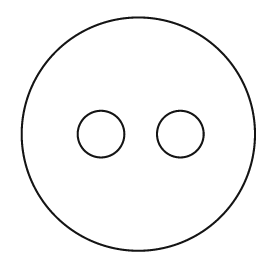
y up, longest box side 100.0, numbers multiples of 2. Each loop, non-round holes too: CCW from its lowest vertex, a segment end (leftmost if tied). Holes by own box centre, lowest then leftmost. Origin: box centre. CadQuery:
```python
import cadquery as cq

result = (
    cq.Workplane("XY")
    .moveTo(0.0, 0.0)
    .circle(50.0)
    .moveTo(-16.0, 0.0)
    .circle(10.0)
    .moveTo(18.0, 0.0)
    .circle(10.0)
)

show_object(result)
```